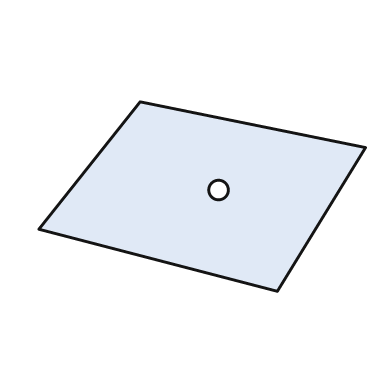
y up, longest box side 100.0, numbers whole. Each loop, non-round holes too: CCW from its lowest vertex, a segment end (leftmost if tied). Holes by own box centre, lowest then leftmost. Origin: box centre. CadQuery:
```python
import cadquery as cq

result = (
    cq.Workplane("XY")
    .moveTo(23.0, -29.0)
    .lineTo(50.0, 15.0)
    .lineTo(-19.0, 29.0)
    .lineTo(-50.0, -10.0)
    .close()
    .moveTo(5.0, 2.0)
    .circle(3.0)
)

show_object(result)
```